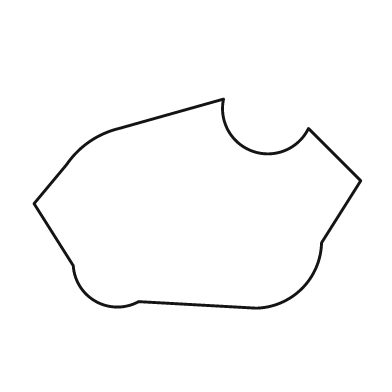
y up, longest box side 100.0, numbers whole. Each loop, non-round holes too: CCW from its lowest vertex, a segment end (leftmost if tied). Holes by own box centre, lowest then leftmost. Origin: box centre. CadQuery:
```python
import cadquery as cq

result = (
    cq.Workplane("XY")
    .moveTo(18.0, -32.0)
    .threePointArc((32.0, -26.0), (38.0, -12.0))
    .lineTo(50.0, 7.0)
    .lineTo(34.0, 23.0)
    .threePointArc((17.0, 16.0), (8.0, 32.0))
    .lineTo(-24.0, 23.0)
    .threePointArc((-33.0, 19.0), (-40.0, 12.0))
    .lineTo(-50.0, 0.0)
    .lineTo(-38.0, -19.0)
    .threePointArc((-31.0, -30.0), (-18.0, -30.0))
    .close()
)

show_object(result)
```